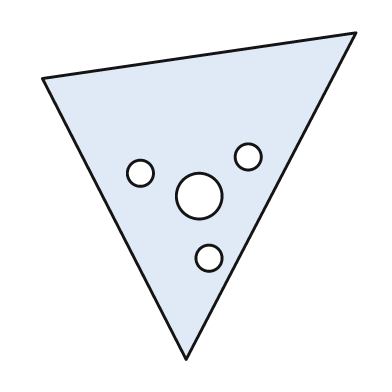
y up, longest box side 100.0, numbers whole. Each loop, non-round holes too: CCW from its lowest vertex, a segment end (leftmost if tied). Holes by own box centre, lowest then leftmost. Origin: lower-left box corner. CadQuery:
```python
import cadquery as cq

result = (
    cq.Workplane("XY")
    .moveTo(44.0, 0.0)
    .lineTo(96.0, 100.0)
    .lineTo(0.0, 86.0)
    .close()
    .moveTo(51.0, 31.0)
    .circle(4.0)
    .moveTo(48.0, 50.0)
    .circle(7.0)
    .moveTo(30.0, 57.0)
    .circle(4.0)
    .moveTo(63.0, 62.0)
    .circle(4.0)
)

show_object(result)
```